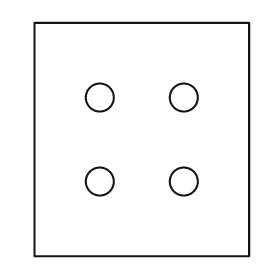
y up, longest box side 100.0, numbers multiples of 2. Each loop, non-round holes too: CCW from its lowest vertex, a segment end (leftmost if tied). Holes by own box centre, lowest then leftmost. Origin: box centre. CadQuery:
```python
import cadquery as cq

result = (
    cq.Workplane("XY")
    .moveTo(-46.0, -50.0)
    .lineTo(46.0, -50.0)
    .lineTo(46.0, 50.0)
    .lineTo(-46.0, 50.0)
    .close()
    .moveTo(-18.0, -18.0)
    .circle(6.0)
    .moveTo(18.0, -18.0)
    .circle(6.0)
    .moveTo(-18.0, 18.0)
    .circle(6.0)
    .moveTo(18.0, 18.0)
    .circle(6.0)
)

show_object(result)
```